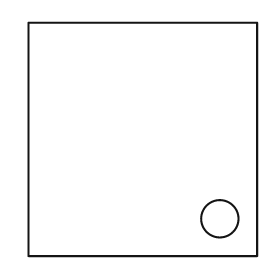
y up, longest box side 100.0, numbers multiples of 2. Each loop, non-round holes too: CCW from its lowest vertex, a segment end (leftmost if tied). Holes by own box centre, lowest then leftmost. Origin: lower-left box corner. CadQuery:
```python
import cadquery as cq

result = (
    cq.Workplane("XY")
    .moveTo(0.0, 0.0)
    .lineTo(98.0, 0.0)
    .lineTo(98.0, 100.0)
    .lineTo(0.0, 100.0)
    .close()
    .moveTo(82.0, 16.0)
    .circle(8.0)
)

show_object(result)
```